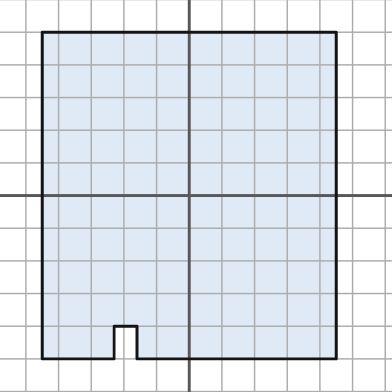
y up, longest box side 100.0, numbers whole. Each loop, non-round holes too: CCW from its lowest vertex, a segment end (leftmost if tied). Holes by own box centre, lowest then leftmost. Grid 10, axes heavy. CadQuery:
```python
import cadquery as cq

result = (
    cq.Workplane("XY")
    .moveTo(-45.0, -50.0)
    .lineTo(-23.0, -50.0)
    .lineTo(-23.0, -40.0)
    .lineTo(-16.0, -40.0)
    .lineTo(-16.0, -50.0)
    .lineTo(45.0, -50.0)
    .lineTo(45.0, 50.0)
    .lineTo(-45.0, 50.0)
    .close()
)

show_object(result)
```